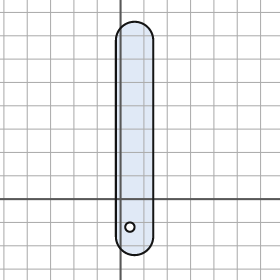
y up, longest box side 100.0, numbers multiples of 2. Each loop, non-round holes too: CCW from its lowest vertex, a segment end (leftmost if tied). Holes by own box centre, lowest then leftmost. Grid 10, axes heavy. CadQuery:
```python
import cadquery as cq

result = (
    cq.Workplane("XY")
    .moveTo(-2.0, -16.0)
    .threePointArc((6.0, -24.0), (14.0, -16.0))
    .lineTo(14.0, 68.0)
    .threePointArc((6.0, 76.0), (-2.0, 68.0))
    .close()
    .moveTo(4.0, -12.0)
    .circle(2.0)
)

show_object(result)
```